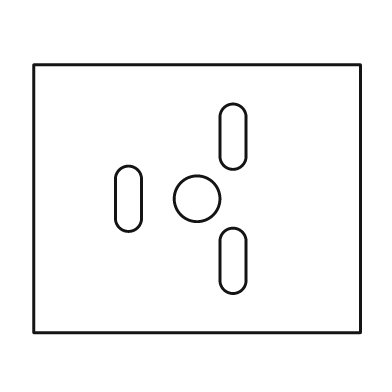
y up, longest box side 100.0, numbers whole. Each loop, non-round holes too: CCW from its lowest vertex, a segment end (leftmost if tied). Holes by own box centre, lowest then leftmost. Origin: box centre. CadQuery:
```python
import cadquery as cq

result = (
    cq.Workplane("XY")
    .moveTo(-50.0, -41.0)
    .lineTo(50.0, -41.0)
    .lineTo(50.0, 41.0)
    .lineTo(-50.0, 41.0)
    .close()
    .moveTo(7.0, -25.0)
    .threePointArc((11.0, -29.0), (15.0, -25.0))
    .lineTo(15.0, -13.0)
    .threePointArc((11.0, -9.0), (7.0, -13.0))
    .close()
    .moveTo(-25.0, -6.0)
    .threePointArc((-21.0, -10.0), (-17.0, -6.0))
    .lineTo(-17.0, 6.0)
    .threePointArc((-21.0, 10.0), (-25.0, 6.0))
    .close()
    .moveTo(0.0, 0.0)
    .circle(7.0)
    .moveTo(7.0, 13.0)
    .threePointArc((11.0, 9.0), (15.0, 13.0))
    .lineTo(15.0, 25.0)
    .threePointArc((11.0, 29.0), (7.0, 25.0))
    .close()
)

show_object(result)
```